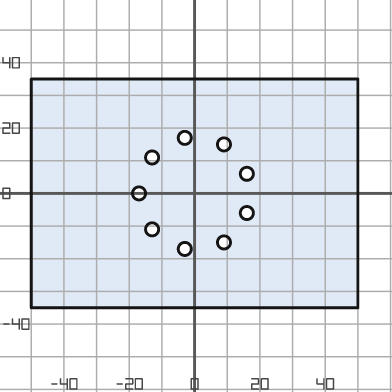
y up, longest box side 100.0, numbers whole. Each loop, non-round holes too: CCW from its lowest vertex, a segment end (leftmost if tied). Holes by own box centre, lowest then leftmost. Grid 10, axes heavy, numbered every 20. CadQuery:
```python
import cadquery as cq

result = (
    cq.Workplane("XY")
    .moveTo(-50.0, -35.0)
    .lineTo(50.0, -35.0)
    .lineTo(50.0, 35.0)
    .lineTo(-50.0, 35.0)
    .close()
    .moveTo(-3.0, -17.0)
    .circle(2.0)
    .moveTo(9.0, -15.0)
    .circle(2.0)
    .moveTo(-13.0, -11.0)
    .circle(2.0)
    .moveTo(16.0, -6.0)
    .circle(2.0)
    .moveTo(-17.0, 0.0)
    .circle(2.0)
    .moveTo(16.0, 6.0)
    .circle(2.0)
    .moveTo(-13.0, 11.0)
    .circle(2.0)
    .moveTo(9.0, 15.0)
    .circle(2.0)
    .moveTo(-3.0, 17.0)
    .circle(2.0)
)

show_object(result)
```